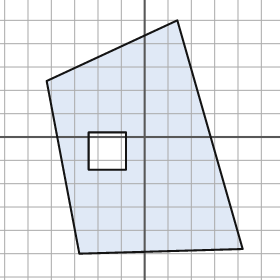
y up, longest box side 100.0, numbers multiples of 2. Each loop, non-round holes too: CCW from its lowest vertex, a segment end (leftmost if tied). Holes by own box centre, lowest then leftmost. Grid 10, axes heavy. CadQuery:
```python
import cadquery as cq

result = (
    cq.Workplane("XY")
    .moveTo(-28.0, -50.0)
    .lineTo(42.0, -48.0)
    .lineTo(14.0, 50.0)
    .lineTo(-42.0, 24.0)
    .close()
    .moveTo(-24.0, -14.0)
    .lineTo(-8.0, -14.0)
    .lineTo(-8.0, 2.0)
    .lineTo(-24.0, 2.0)
    .close()
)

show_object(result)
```